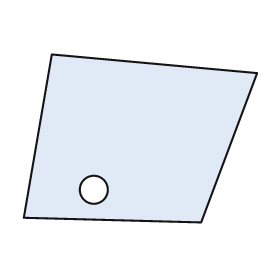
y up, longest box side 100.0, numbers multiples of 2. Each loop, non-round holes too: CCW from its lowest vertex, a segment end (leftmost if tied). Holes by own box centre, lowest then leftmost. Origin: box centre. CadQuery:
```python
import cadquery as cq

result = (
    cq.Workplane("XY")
    .moveTo(26.0, -36.0)
    .lineTo(50.0, 28.0)
    .lineTo(-38.0, 36.0)
    .lineTo(-50.0, -34.0)
    .close()
    .moveTo(-20.0, -22.0)
    .circle(6.0)
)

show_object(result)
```